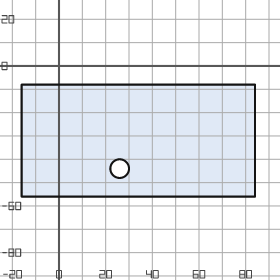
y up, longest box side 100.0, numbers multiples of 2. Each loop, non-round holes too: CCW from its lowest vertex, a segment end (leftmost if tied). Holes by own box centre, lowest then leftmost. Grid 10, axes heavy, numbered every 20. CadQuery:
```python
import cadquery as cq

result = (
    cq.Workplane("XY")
    .moveTo(-16.0, -56.0)
    .lineTo(84.0, -56.0)
    .lineTo(84.0, -8.0)
    .lineTo(-16.0, -8.0)
    .close()
    .moveTo(26.0, -44.0)
    .circle(4.0)
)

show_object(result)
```